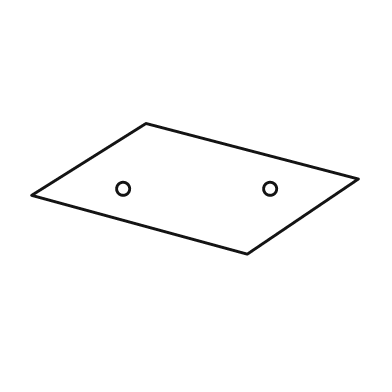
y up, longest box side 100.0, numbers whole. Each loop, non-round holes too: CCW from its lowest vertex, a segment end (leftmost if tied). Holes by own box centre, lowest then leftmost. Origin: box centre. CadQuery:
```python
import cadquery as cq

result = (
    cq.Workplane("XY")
    .moveTo(16.0, -20.0)
    .lineTo(50.0, 3.0)
    .lineTo(-15.0, 20.0)
    .lineTo(-50.0, -2.0)
    .close()
    .moveTo(-22.0, 0.0)
    .circle(2.0)
    .moveTo(23.0, 0.0)
    .circle(2.0)
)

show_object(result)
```